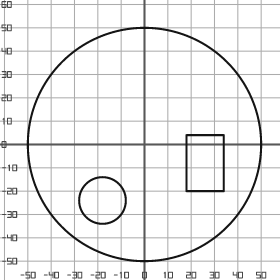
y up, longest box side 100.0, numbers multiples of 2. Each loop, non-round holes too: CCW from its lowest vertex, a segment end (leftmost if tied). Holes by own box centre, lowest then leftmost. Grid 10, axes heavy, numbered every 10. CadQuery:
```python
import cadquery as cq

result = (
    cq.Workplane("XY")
    .moveTo(0.0, 0.0)
    .circle(50.0)
    .moveTo(-18.0, -24.0)
    .circle(10.0)
    .moveTo(18.0, -20.0)
    .lineTo(34.0, -20.0)
    .lineTo(34.0, 4.0)
    .lineTo(18.0, 4.0)
    .close()
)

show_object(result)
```